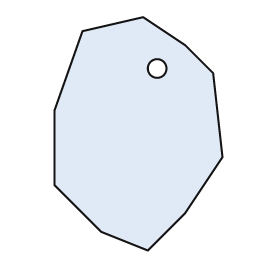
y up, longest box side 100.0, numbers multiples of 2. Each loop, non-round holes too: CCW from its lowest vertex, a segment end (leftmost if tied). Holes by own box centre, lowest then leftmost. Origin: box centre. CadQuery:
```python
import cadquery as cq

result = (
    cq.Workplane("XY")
    .moveTo(4.0, -50.0)
    .lineTo(20.0, -34.0)
    .lineTo(36.0, -10.0)
    .lineTo(32.0, 26.0)
    .lineTo(20.0, 38.0)
    .lineTo(2.0, 50.0)
    .lineTo(-24.0, 44.0)
    .lineTo(-36.0, 10.0)
    .lineTo(-36.0, -22.0)
    .lineTo(-16.0, -42.0)
    .close()
    .moveTo(8.0, 28.0)
    .circle(4.0)
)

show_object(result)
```